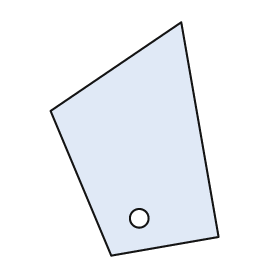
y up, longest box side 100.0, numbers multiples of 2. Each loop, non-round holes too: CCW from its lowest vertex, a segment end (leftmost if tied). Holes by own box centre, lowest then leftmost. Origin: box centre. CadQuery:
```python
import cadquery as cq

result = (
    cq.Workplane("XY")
    .moveTo(-10.0, -50.0)
    .lineTo(36.0, -42.0)
    .lineTo(20.0, 50.0)
    .lineTo(-36.0, 12.0)
    .close()
    .moveTo(2.0, -34.0)
    .circle(4.0)
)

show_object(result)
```